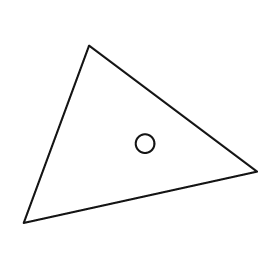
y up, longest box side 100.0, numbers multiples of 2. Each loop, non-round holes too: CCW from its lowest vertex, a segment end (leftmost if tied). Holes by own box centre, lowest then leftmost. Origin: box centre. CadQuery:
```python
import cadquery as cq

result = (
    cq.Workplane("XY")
    .moveTo(-50.0, -38.0)
    .lineTo(50.0, -16.0)
    .lineTo(-22.0, 38.0)
    .close()
    .moveTo(2.0, -4.0)
    .circle(4.0)
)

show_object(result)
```